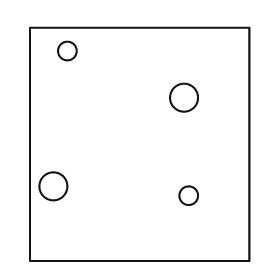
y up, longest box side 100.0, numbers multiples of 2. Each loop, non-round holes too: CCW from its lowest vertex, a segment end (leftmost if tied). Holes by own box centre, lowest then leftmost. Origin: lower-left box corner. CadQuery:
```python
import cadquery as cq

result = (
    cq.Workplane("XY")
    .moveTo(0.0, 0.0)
    .lineTo(94.0, 0.0)
    .lineTo(94.0, 100.0)
    .lineTo(0.0, 100.0)
    .close()
    .moveTo(68.0, 28.0)
    .circle(4.0)
    .moveTo(10.0, 32.0)
    .circle(6.0)
    .moveTo(66.0, 70.0)
    .circle(6.0)
    .moveTo(16.0, 90.0)
    .circle(4.0)
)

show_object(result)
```